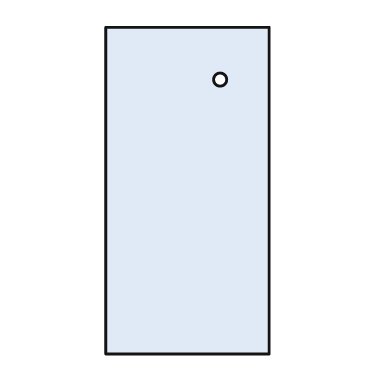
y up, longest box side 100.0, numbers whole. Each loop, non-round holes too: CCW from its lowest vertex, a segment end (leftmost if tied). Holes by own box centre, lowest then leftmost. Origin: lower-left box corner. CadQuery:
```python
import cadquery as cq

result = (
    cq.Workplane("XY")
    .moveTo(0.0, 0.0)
    .lineTo(50.0, 0.0)
    .lineTo(50.0, 100.0)
    .lineTo(0.0, 100.0)
    .close()
    .moveTo(35.0, 84.0)
    .circle(2.0)
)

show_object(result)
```